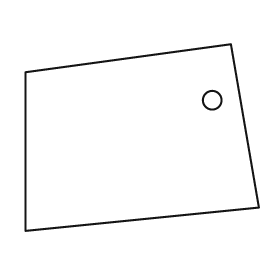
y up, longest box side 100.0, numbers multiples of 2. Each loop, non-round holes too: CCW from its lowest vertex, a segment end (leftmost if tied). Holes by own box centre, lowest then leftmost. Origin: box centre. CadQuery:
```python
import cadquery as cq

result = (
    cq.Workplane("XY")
    .moveTo(-50.0, -40.0)
    .lineTo(50.0, -30.0)
    .lineTo(38.0, 40.0)
    .lineTo(-50.0, 28.0)
    .close()
    .moveTo(30.0, 16.0)
    .circle(4.0)
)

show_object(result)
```